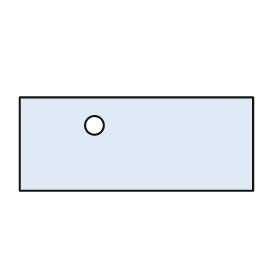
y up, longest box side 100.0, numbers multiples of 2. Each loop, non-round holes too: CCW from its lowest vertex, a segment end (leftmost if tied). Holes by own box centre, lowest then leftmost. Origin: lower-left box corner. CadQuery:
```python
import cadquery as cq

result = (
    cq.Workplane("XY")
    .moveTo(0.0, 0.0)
    .lineTo(100.0, 0.0)
    .lineTo(100.0, 40.0)
    .lineTo(0.0, 40.0)
    .close()
    .moveTo(32.0, 28.0)
    .circle(4.0)
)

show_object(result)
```